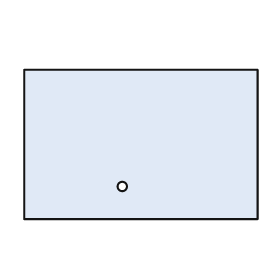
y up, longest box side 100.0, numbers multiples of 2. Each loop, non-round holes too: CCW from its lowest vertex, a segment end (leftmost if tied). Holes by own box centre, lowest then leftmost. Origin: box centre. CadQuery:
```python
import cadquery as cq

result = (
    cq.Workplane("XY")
    .moveTo(-50.0, -32.0)
    .lineTo(50.0, -32.0)
    .lineTo(50.0, 32.0)
    .lineTo(-50.0, 32.0)
    .close()
    .moveTo(-8.0, -18.0)
    .circle(2.0)
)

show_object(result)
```